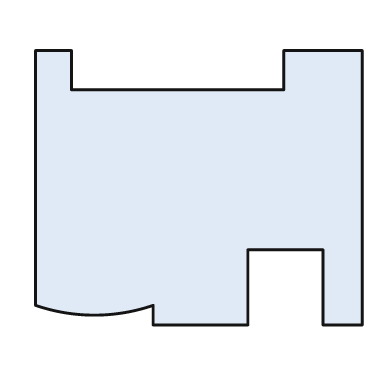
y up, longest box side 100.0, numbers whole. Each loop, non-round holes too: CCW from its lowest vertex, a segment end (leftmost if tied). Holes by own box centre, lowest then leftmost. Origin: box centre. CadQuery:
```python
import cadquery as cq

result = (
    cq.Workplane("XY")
    .moveTo(-14.0, -42.0)
    .lineTo(15.0, -42.0)
    .lineTo(15.0, -19.0)
    .lineTo(38.0, -19.0)
    .lineTo(38.0, -42.0)
    .lineTo(50.0, -42.0)
    .lineTo(50.0, 42.0)
    .lineTo(26.0, 42.0)
    .lineTo(26.0, 30.0)
    .lineTo(-39.0, 30.0)
    .lineTo(-39.0, 42.0)
    .lineTo(-50.0, 42.0)
    .lineTo(-50.0, -36.0)
    .threePointArc((-32.0, -39.0), (-14.0, -36.0))
    .close()
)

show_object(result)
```